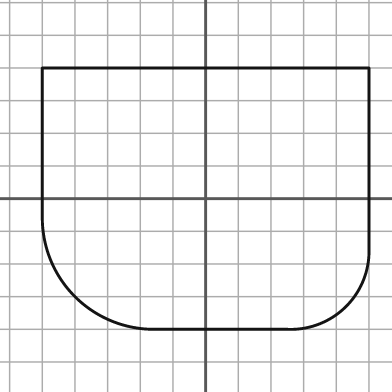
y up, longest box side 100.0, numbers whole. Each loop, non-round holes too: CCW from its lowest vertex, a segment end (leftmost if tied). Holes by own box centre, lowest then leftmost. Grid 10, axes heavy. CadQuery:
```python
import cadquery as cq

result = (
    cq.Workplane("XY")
    .moveTo(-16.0, -40.0)
    .lineTo(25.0, -40.0)
    .threePointArc((43.0, -33.0), (50.0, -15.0))
    .lineTo(50.0, 40.0)
    .lineTo(-50.0, 40.0)
    .lineTo(-50.0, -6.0)
    .threePointArc((-40.0, -30.0), (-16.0, -40.0))
    .close()
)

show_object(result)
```